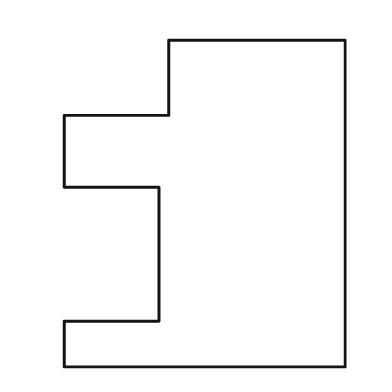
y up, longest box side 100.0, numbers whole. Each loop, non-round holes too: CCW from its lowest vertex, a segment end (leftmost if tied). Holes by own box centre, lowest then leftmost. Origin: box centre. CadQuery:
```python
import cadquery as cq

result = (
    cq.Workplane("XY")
    .moveTo(-43.0, -50.0)
    .lineTo(43.0, -50.0)
    .lineTo(43.0, 50.0)
    .lineTo(-11.0, 50.0)
    .lineTo(-11.0, 27.0)
    .lineTo(-43.0, 27.0)
    .lineTo(-43.0, 5.0)
    .lineTo(-14.0, 5.0)
    .lineTo(-14.0, -36.0)
    .lineTo(-43.0, -36.0)
    .close()
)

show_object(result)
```